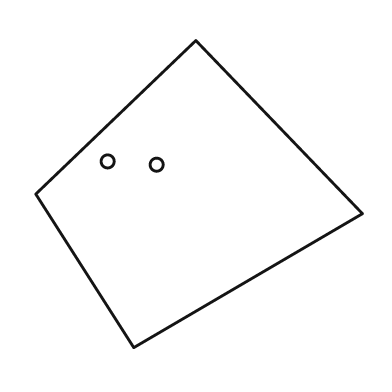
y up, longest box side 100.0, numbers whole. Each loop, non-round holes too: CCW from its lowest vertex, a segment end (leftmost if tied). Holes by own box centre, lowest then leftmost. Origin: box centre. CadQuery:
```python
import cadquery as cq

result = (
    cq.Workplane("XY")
    .moveTo(-20.0, -47.0)
    .lineTo(50.0, -6.0)
    .lineTo(-1.0, 47.0)
    .lineTo(-50.0, 0.0)
    .close()
    .moveTo(-13.0, 9.0)
    .circle(2.0)
    .moveTo(-28.0, 10.0)
    .circle(2.0)
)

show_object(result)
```